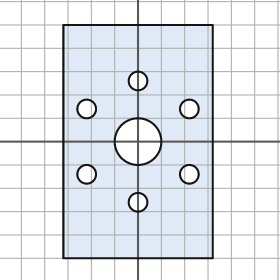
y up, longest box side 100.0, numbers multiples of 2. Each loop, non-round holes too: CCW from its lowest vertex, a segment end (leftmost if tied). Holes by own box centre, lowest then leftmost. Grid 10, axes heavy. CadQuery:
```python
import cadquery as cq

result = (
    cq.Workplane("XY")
    .moveTo(-32.0, -50.0)
    .lineTo(32.0, -50.0)
    .lineTo(32.0, 50.0)
    .lineTo(-32.0, 50.0)
    .close()
    .moveTo(0.0, -26.0)
    .circle(4.0)
    .moveTo(-22.0, -14.0)
    .circle(4.0)
    .moveTo(22.0, -14.0)
    .circle(4.0)
    .moveTo(0.0, 0.0)
    .circle(10.0)
    .moveTo(-22.0, 14.0)
    .circle(4.0)
    .moveTo(22.0, 14.0)
    .circle(4.0)
    .moveTo(0.0, 26.0)
    .circle(4.0)
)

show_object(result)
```